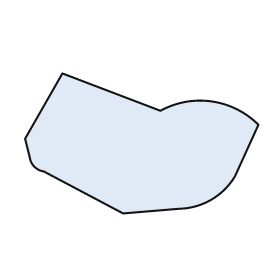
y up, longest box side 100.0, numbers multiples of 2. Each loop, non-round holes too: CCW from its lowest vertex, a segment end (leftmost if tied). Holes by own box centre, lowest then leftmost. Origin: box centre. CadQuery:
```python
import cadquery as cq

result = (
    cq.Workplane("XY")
    .moveTo(-8.0, -30.0)
    .lineTo(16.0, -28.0)
    .threePointArc((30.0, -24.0), (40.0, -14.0))
    .lineTo(50.0, 8.0)
    .threePointArc((30.0, 18.0), (8.0, 14.0))
    .lineTo(-34.0, 30.0)
    .lineTo(-50.0, 2.0)
    .lineTo(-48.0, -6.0)
    .threePointArc((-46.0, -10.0), (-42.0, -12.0))
    .close()
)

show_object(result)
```